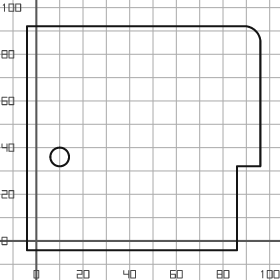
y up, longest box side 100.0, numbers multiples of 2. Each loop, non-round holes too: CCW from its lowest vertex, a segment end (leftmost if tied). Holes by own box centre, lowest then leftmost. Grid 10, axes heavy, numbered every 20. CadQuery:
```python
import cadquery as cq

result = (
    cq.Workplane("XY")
    .moveTo(-4.0, -4.0)
    .lineTo(86.0, -4.0)
    .lineTo(86.0, 32.0)
    .lineTo(96.0, 32.0)
    .lineTo(96.0, 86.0)
    .threePointArc((94.0, 90.0), (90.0, 92.0))
    .lineTo(-4.0, 92.0)
    .close()
    .moveTo(10.0, 36.0)
    .circle(4.0)
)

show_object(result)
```